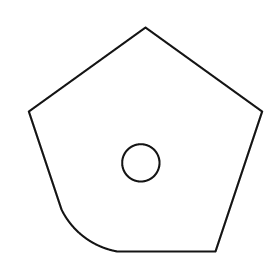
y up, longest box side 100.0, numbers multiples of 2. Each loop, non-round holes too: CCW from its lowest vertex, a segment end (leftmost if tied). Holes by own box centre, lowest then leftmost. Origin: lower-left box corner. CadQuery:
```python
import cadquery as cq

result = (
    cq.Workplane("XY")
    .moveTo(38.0, 0.0)
    .lineTo(80.0, 0.0)
    .lineTo(100.0, 60.0)
    .lineTo(50.0, 96.0)
    .lineTo(0.0, 60.0)
    .lineTo(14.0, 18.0)
    .threePointArc((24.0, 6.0), (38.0, 0.0))
    .close()
    .moveTo(48.0, 38.0)
    .circle(8.0)
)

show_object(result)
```